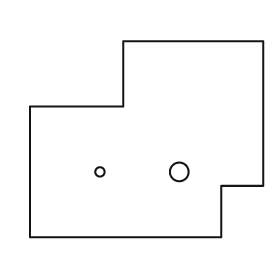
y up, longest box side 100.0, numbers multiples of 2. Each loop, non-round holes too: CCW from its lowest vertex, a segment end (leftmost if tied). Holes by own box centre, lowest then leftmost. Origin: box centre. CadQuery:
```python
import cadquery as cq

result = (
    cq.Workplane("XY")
    .moveTo(-50.0, -42.0)
    .lineTo(32.0, -42.0)
    .lineTo(32.0, -20.0)
    .lineTo(50.0, -20.0)
    .lineTo(50.0, 42.0)
    .lineTo(-10.0, 42.0)
    .lineTo(-10.0, 14.0)
    .lineTo(-50.0, 14.0)
    .close()
    .moveTo(-20.0, -14.0)
    .circle(2.0)
    .moveTo(14.0, -14.0)
    .circle(4.0)
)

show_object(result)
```